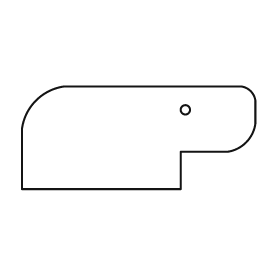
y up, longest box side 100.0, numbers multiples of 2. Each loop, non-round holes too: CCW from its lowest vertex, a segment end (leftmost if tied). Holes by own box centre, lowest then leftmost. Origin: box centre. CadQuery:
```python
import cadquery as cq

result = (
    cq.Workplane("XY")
    .moveTo(-50.0, -22.0)
    .lineTo(18.0, -22.0)
    .lineTo(18.0, -6.0)
    .lineTo(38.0, -6.0)
    .threePointArc((46.0, -2.0), (50.0, 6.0))
    .lineTo(50.0, 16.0)
    .threePointArc((48.0, 20.0), (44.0, 22.0))
    .lineTo(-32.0, 22.0)
    .threePointArc((-44.0, 16.0), (-50.0, 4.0))
    .close()
    .moveTo(20.0, 12.0)
    .circle(2.0)
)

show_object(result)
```